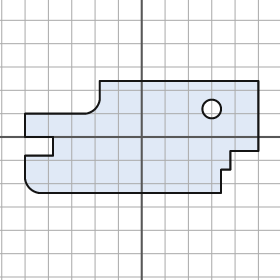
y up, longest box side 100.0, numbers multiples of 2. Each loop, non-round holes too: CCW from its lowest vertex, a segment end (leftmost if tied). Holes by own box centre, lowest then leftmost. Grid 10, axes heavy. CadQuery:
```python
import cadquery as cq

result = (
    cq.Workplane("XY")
    .moveTo(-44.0, -24.0)
    .lineTo(34.0, -24.0)
    .lineTo(34.0, -14.0)
    .lineTo(38.0, -14.0)
    .lineTo(38.0, -6.0)
    .lineTo(50.0, -6.0)
    .lineTo(50.0, 24.0)
    .lineTo(-18.0, 24.0)
    .lineTo(-18.0, 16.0)
    .threePointArc((-20.0, 12.0), (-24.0, 10.0))
    .lineTo(-50.0, 10.0)
    .lineTo(-50.0, 0.0)
    .lineTo(-38.0, 0.0)
    .lineTo(-38.0, -8.0)
    .lineTo(-50.0, -8.0)
    .lineTo(-50.0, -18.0)
    .threePointArc((-48.0, -22.0), (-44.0, -24.0))
    .close()
    .moveTo(30.0, 12.0)
    .circle(4.0)
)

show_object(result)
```